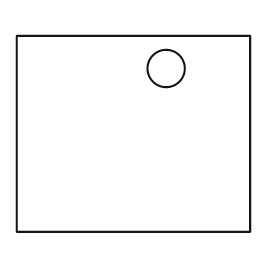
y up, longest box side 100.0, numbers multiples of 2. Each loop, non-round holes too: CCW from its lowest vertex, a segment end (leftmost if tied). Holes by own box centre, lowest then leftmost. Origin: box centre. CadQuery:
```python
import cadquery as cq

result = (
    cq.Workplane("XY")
    .moveTo(-50.0, -42.0)
    .lineTo(50.0, -42.0)
    .lineTo(50.0, 42.0)
    .lineTo(-50.0, 42.0)
    .close()
    .moveTo(14.0, 28.0)
    .circle(8.0)
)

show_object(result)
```